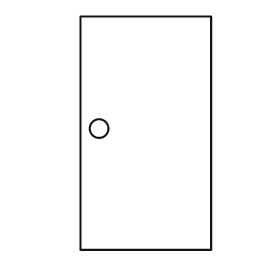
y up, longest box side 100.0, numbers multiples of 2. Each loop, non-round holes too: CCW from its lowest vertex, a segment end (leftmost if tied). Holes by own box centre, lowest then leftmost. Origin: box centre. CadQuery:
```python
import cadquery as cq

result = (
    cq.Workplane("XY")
    .moveTo(-28.0, -50.0)
    .lineTo(28.0, -50.0)
    .lineTo(28.0, 50.0)
    .lineTo(-28.0, 50.0)
    .close()
    .moveTo(-20.0, 2.0)
    .circle(4.0)
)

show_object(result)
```